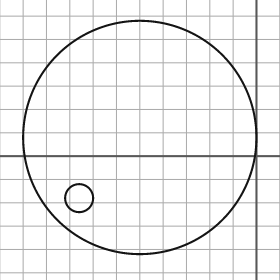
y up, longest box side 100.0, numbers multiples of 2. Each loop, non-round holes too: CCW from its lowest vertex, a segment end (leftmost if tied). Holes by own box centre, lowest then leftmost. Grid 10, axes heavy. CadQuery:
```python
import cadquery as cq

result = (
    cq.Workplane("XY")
    .moveTo(-50.0, 8.0)
    .circle(50.0)
    .moveTo(-76.0, -18.0)
    .circle(6.0)
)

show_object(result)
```